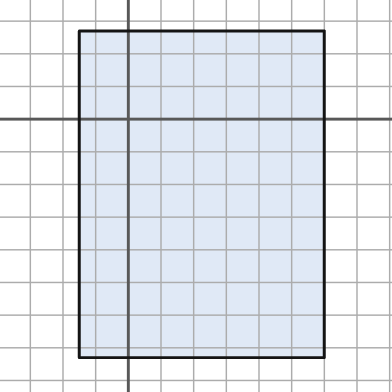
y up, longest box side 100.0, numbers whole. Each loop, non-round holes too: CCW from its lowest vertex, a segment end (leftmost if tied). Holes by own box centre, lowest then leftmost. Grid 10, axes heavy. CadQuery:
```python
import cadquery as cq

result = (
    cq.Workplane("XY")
    .moveTo(-15.0, -73.0)
    .lineTo(60.0, -73.0)
    .lineTo(60.0, 27.0)
    .lineTo(-15.0, 27.0)
    .close()
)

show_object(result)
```